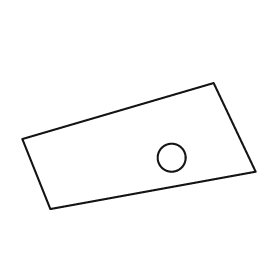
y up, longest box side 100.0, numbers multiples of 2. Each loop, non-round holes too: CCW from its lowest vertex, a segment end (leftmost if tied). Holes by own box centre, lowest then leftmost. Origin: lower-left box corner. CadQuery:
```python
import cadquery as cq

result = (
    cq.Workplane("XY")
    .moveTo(12.0, 0.0)
    .lineTo(100.0, 16.0)
    .lineTo(82.0, 54.0)
    .lineTo(0.0, 30.0)
    .close()
    .moveTo(64.0, 22.0)
    .circle(6.0)
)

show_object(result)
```